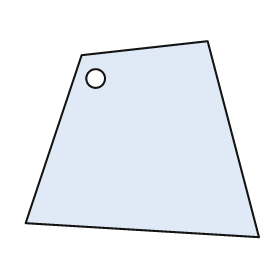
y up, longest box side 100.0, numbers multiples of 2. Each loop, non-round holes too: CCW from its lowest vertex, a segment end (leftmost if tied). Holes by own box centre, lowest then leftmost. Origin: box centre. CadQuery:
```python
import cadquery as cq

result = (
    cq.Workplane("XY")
    .moveTo(50.0, -42.0)
    .lineTo(28.0, 42.0)
    .lineTo(-26.0, 36.0)
    .lineTo(-50.0, -36.0)
    .close()
    .moveTo(-20.0, 26.0)
    .circle(4.0)
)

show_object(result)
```